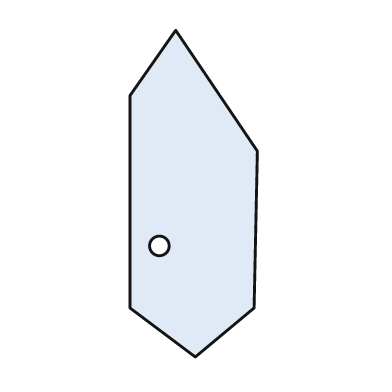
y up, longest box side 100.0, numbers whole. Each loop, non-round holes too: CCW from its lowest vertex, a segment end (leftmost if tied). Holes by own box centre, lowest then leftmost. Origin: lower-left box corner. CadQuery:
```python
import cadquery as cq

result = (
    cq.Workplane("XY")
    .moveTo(20.0, 0.0)
    .lineTo(38.0, 15.0)
    .lineTo(39.0, 63.0)
    .lineTo(14.0, 100.0)
    .lineTo(0.0, 80.0)
    .lineTo(0.0, 15.0)
    .close()
    .moveTo(9.0, 34.0)
    .circle(3.0)
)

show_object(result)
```